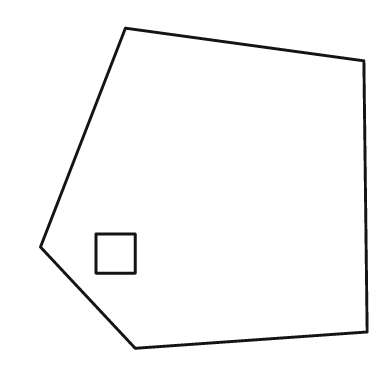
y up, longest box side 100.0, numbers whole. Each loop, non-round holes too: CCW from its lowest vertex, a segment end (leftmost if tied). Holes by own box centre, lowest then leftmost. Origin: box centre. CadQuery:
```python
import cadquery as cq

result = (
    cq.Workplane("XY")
    .moveTo(-21.0, -49.0)
    .lineTo(50.0, -44.0)
    .lineTo(49.0, 39.0)
    .lineTo(-24.0, 49.0)
    .lineTo(-50.0, -18.0)
    .close()
    .moveTo(-33.0, -26.0)
    .lineTo(-21.0, -26.0)
    .lineTo(-21.0, -14.0)
    .lineTo(-33.0, -14.0)
    .close()
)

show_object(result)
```